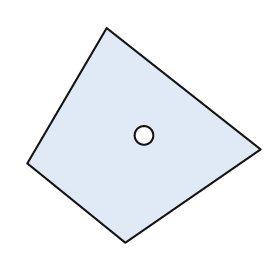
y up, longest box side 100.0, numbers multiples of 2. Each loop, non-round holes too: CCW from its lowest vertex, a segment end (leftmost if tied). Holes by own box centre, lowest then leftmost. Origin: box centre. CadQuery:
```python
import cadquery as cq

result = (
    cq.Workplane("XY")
    .moveTo(-8.0, -46.0)
    .lineTo(50.0, -6.0)
    .lineTo(-16.0, 46.0)
    .lineTo(-50.0, -12.0)
    .close()
    .moveTo(0.0, 0.0)
    .circle(4.0)
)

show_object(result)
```